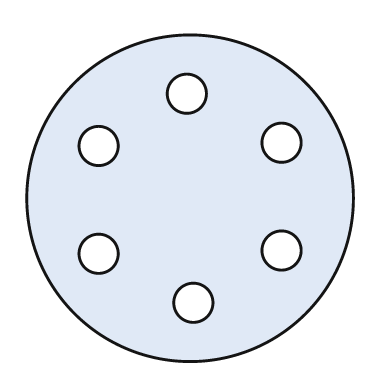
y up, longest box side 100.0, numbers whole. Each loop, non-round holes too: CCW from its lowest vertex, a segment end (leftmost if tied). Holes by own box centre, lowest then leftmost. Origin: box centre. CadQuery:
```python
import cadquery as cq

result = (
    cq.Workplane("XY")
    .moveTo(0.0, 0.0)
    .circle(50.0)
    .moveTo(1.0, -32.0)
    .circle(6.0)
    .moveTo(-28.0, -17.0)
    .circle(6.0)
    .moveTo(28.0, -16.0)
    .circle(6.0)
    .moveTo(-28.0, 16.0)
    .circle(6.0)
    .moveTo(28.0, 17.0)
    .circle(6.0)
    .moveTo(-1.0, 32.0)
    .circle(6.0)
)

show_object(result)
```